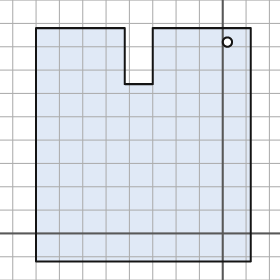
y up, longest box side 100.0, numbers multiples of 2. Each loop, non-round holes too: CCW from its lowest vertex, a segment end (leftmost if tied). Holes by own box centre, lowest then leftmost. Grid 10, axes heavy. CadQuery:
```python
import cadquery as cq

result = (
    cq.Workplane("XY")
    .moveTo(-80.0, -12.0)
    .lineTo(12.0, -12.0)
    .lineTo(12.0, 88.0)
    .lineTo(-30.0, 88.0)
    .lineTo(-30.0, 64.0)
    .lineTo(-42.0, 64.0)
    .lineTo(-42.0, 88.0)
    .lineTo(-80.0, 88.0)
    .close()
    .moveTo(2.0, 82.0)
    .circle(2.0)
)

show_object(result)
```